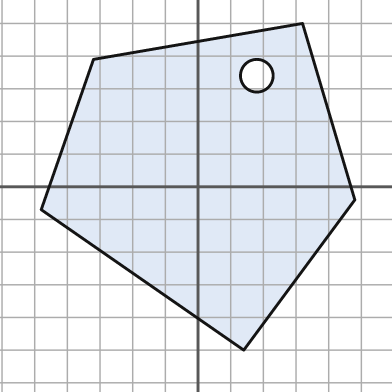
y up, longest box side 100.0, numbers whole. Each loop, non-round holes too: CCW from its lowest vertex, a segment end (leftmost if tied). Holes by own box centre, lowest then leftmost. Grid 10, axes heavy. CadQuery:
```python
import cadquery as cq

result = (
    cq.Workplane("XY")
    .moveTo(14.0, -50.0)
    .lineTo(48.0, -4.0)
    .lineTo(32.0, 50.0)
    .lineTo(-32.0, 39.0)
    .lineTo(-48.0, -7.0)
    .close()
    .moveTo(18.0, 34.0)
    .circle(5.0)
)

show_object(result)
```